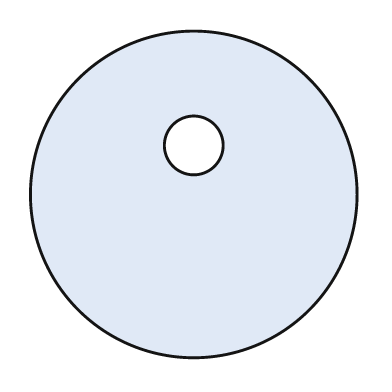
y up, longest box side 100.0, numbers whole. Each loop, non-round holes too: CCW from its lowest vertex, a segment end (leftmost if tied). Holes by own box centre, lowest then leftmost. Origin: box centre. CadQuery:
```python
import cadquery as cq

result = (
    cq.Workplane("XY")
    .moveTo(0.0, 0.0)
    .circle(50.0)
    .moveTo(0.0, 15.0)
    .circle(9.0)
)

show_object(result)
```